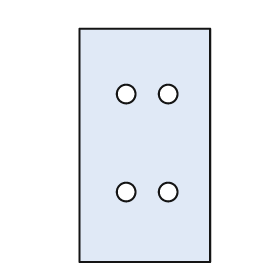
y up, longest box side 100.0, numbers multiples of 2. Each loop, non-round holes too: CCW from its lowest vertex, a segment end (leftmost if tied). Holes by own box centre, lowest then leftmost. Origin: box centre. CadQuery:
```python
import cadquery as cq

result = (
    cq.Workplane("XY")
    .moveTo(-28.0, -50.0)
    .lineTo(28.0, -50.0)
    .lineTo(28.0, 50.0)
    .lineTo(-28.0, 50.0)
    .close()
    .moveTo(-8.0, -20.0)
    .circle(4.0)
    .moveTo(10.0, -20.0)
    .circle(4.0)
    .moveTo(-8.0, 22.0)
    .circle(4.0)
    .moveTo(10.0, 22.0)
    .circle(4.0)
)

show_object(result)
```